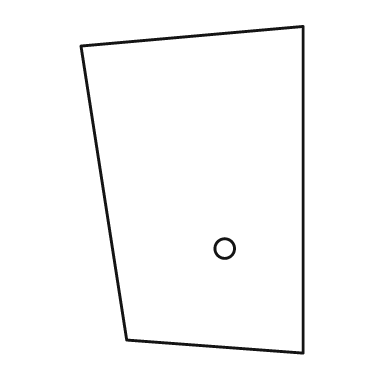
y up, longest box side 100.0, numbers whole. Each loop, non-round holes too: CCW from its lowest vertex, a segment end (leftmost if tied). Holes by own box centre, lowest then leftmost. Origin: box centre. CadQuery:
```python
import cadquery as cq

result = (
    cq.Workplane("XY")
    .moveTo(34.0, -50.0)
    .lineTo(34.0, 50.0)
    .lineTo(-34.0, 44.0)
    .lineTo(-20.0, -46.0)
    .close()
    .moveTo(10.0, -18.0)
    .circle(3.0)
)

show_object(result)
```